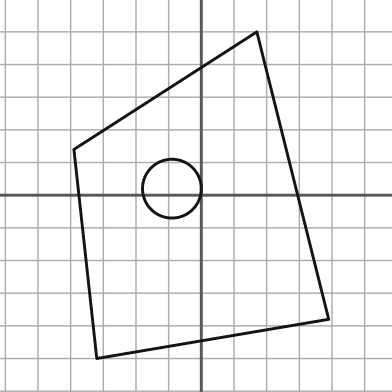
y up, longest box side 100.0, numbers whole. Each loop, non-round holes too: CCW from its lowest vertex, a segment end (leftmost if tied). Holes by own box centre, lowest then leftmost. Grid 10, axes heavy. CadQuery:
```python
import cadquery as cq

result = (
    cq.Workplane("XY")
    .moveTo(-32.0, -50.0)
    .lineTo(39.0, -38.0)
    .lineTo(17.0, 50.0)
    .lineTo(-39.0, 14.0)
    .close()
    .moveTo(-9.0, 2.0)
    .circle(9.0)
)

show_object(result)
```